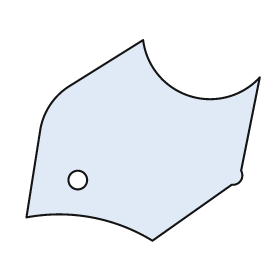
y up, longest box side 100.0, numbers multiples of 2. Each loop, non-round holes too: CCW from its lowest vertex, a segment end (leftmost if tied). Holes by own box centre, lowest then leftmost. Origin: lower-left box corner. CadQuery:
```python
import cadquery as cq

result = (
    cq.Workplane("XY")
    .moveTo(54.0, 0.0)
    .lineTo(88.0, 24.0)
    .threePointArc((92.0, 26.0), (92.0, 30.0))
    .lineTo(100.0, 70.0)
    .threePointArc((70.0, 62.0), (50.0, 86.0))
    .lineTo(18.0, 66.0)
    .threePointArc((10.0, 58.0), (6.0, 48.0))
    .lineTo(0.0, 10.0)
    .threePointArc((28.0, 10.0), (54.0, 0.0))
    .close()
    .moveTo(22.0, 26.0)
    .circle(4.0)
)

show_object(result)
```